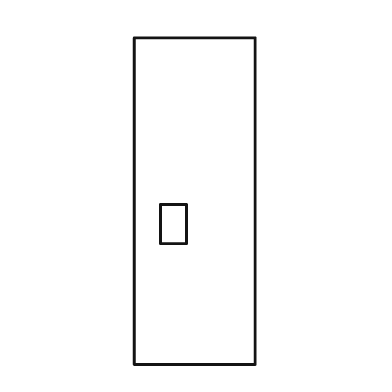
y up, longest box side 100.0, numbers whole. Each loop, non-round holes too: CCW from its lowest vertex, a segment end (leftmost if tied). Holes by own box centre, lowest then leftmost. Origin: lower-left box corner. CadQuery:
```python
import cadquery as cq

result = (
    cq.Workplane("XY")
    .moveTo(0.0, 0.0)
    .lineTo(37.0, 0.0)
    .lineTo(37.0, 100.0)
    .lineTo(0.0, 100.0)
    .close()
    .moveTo(8.0, 37.0)
    .lineTo(16.0, 37.0)
    .lineTo(16.0, 49.0)
    .lineTo(8.0, 49.0)
    .close()
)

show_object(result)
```